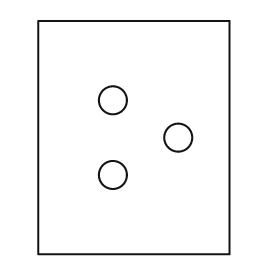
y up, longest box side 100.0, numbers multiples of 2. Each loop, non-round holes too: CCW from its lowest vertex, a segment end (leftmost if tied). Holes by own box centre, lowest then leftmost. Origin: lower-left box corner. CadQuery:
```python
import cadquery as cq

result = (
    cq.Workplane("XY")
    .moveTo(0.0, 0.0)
    .lineTo(82.0, 0.0)
    .lineTo(82.0, 100.0)
    .lineTo(0.0, 100.0)
    .close()
    .moveTo(32.0, 34.0)
    .circle(6.0)
    .moveTo(60.0, 50.0)
    .circle(6.0)
    .moveTo(32.0, 66.0)
    .circle(6.0)
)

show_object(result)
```